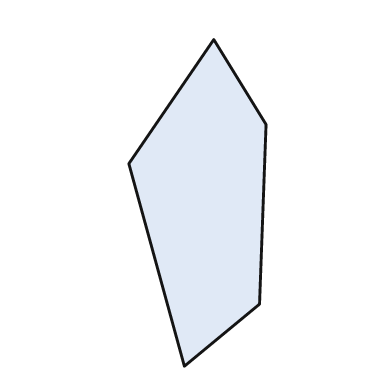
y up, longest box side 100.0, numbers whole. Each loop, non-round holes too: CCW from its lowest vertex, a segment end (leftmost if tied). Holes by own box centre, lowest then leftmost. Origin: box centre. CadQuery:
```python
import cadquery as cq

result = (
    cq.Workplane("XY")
    .moveTo(-4.0, -50.0)
    .lineTo(19.0, -31.0)
    .lineTo(21.0, 24.0)
    .lineTo(5.0, 50.0)
    .lineTo(-21.0, 12.0)
    .close()
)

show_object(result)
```